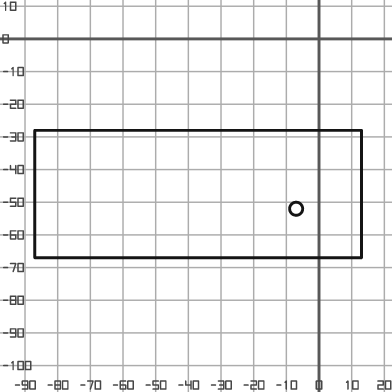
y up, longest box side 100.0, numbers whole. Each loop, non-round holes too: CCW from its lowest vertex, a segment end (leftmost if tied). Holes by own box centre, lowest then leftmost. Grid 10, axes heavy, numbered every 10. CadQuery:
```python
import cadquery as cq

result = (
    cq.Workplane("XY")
    .moveTo(-87.0, -67.0)
    .lineTo(13.0, -67.0)
    .lineTo(13.0, -28.0)
    .lineTo(-87.0, -28.0)
    .close()
    .moveTo(-7.0, -52.0)
    .circle(2.0)
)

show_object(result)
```